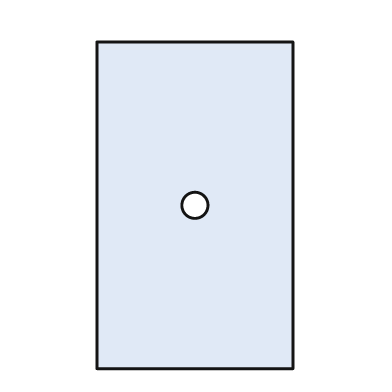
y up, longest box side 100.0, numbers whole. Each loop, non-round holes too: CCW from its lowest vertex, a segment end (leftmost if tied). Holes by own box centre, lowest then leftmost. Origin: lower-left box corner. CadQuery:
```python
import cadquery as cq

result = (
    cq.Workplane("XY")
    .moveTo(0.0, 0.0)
    .lineTo(60.0, 0.0)
    .lineTo(60.0, 100.0)
    .lineTo(0.0, 100.0)
    .close()
    .moveTo(30.0, 50.0)
    .circle(4.0)
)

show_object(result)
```